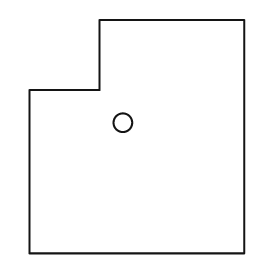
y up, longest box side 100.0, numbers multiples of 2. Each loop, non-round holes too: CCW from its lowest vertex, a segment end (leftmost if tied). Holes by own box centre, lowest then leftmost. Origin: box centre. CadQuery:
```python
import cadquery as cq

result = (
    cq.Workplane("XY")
    .moveTo(-46.0, -50.0)
    .lineTo(46.0, -50.0)
    .lineTo(46.0, 50.0)
    .lineTo(-16.0, 50.0)
    .lineTo(-16.0, 20.0)
    .lineTo(-46.0, 20.0)
    .close()
    .moveTo(-6.0, 6.0)
    .circle(4.0)
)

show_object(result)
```